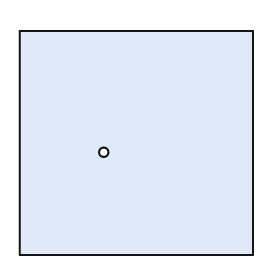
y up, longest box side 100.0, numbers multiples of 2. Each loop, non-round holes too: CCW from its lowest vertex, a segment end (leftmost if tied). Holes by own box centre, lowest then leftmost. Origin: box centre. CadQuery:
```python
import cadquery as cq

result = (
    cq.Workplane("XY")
    .moveTo(-50.0, -48.0)
    .lineTo(50.0, -48.0)
    .lineTo(50.0, 48.0)
    .lineTo(-50.0, 48.0)
    .close()
    .moveTo(-14.0, -4.0)
    .circle(2.0)
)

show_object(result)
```